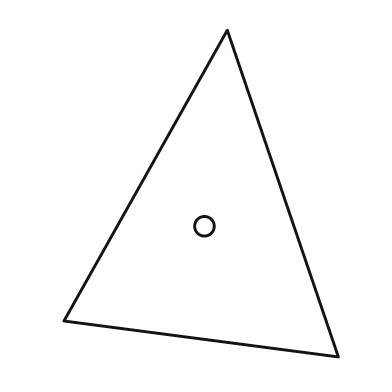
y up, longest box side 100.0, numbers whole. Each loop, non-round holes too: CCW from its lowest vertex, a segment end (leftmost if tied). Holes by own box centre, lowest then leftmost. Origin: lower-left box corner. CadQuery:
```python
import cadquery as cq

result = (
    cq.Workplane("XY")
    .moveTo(84.0, 0.0)
    .lineTo(50.0, 100.0)
    .lineTo(0.0, 11.0)
    .close()
    .moveTo(43.0, 40.0)
    .circle(3.0)
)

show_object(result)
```